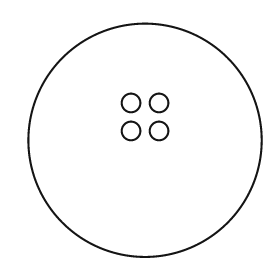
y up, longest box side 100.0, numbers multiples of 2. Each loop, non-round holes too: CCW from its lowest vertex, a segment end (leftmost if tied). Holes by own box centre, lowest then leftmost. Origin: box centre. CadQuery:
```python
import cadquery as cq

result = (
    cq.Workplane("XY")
    .moveTo(0.0, 0.0)
    .circle(50.0)
    .moveTo(-6.0, 4.0)
    .circle(4.0)
    .moveTo(6.0, 4.0)
    .circle(4.0)
    .moveTo(-6.0, 16.0)
    .circle(4.0)
    .moveTo(6.0, 16.0)
    .circle(4.0)
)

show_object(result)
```